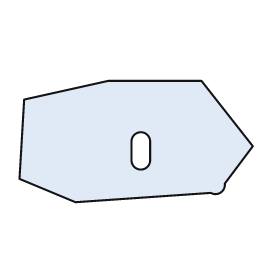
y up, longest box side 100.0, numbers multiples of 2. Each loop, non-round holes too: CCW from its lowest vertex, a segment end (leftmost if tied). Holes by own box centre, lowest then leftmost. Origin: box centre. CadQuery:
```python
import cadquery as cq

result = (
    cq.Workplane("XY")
    .moveTo(-26.0, -26.0)
    .lineTo(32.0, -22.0)
    .threePointArc((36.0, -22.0), (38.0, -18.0))
    .lineTo(50.0, -2.0)
    .lineTo(28.0, 26.0)
    .lineTo(-12.0, 26.0)
    .lineTo(-48.0, 18.0)
    .lineTo(-50.0, -16.0)
    .close()
    .moveTo(-2.0, -8.0)
    .threePointArc((2.0, -12.0), (6.0, -8.0))
    .lineTo(6.0, 0.0)
    .threePointArc((2.0, 4.0), (-2.0, 0.0))
    .close()
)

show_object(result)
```